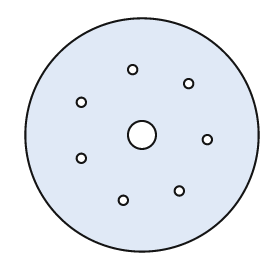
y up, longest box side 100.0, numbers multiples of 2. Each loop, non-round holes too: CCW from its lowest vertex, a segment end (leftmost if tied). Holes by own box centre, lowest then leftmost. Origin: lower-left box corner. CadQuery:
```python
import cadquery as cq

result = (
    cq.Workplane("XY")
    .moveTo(50.0, 50.0)
    .circle(50.0)
    .moveTo(42.0, 22.0)
    .circle(2.0)
    .moveTo(66.0, 26.0)
    .circle(2.0)
    .moveTo(24.0, 40.0)
    .circle(2.0)
    .moveTo(78.0, 48.0)
    .circle(2.0)
    .moveTo(50.0, 50.0)
    .circle(6.0)
    .moveTo(24.0, 64.0)
    .circle(2.0)
    .moveTo(70.0, 72.0)
    .circle(2.0)
    .moveTo(46.0, 78.0)
    .circle(2.0)
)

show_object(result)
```